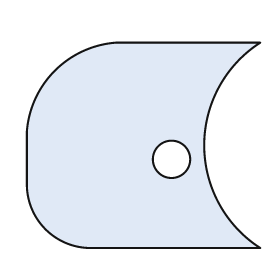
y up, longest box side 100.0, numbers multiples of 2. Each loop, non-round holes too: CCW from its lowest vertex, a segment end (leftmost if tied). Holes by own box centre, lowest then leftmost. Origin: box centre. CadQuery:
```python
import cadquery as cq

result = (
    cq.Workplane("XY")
    .moveTo(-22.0, -44.0)
    .lineTo(50.0, -44.0)
    .threePointArc((26.0, 0.0), (50.0, 44.0))
    .lineTo(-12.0, 44.0)
    .threePointArc((-38.0, 32.0), (-50.0, 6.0))
    .lineTo(-50.0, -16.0)
    .threePointArc((-42.0, -36.0), (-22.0, -44.0))
    .close()
    .moveTo(12.0, -6.0)
    .circle(8.0)
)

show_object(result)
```